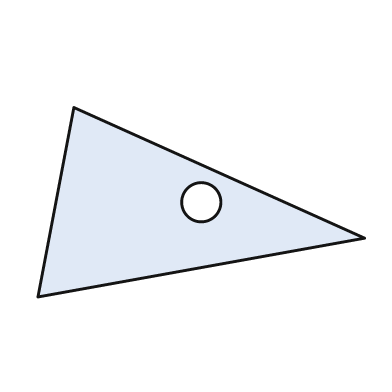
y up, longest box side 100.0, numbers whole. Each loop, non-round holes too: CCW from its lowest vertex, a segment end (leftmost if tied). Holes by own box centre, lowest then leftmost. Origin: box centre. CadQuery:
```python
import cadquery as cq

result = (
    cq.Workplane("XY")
    .moveTo(-50.0, -29.0)
    .lineTo(50.0, -11.0)
    .lineTo(-39.0, 29.0)
    .close()
    .moveTo(0.0, 0.0)
    .circle(6.0)
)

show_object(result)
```